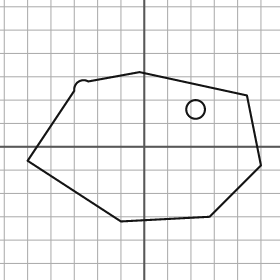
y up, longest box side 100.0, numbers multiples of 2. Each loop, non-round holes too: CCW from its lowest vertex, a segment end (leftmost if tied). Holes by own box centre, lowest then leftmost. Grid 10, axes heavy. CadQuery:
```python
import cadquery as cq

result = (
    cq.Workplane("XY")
    .moveTo(-10.0, -32.0)
    .lineTo(28.0, -30.0)
    .lineTo(50.0, -8.0)
    .lineTo(44.0, 22.0)
    .lineTo(-2.0, 32.0)
    .lineTo(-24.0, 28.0)
    .threePointArc((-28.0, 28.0), (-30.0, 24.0))
    .lineTo(-50.0, -6.0)
    .close()
    .moveTo(22.0, 16.0)
    .circle(4.0)
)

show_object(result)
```